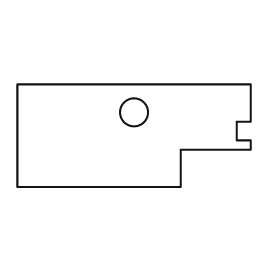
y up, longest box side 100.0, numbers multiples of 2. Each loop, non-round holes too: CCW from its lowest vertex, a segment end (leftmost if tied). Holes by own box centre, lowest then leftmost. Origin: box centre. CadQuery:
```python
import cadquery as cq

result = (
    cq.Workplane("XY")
    .moveTo(-50.0, -22.0)
    .lineTo(20.0, -22.0)
    .lineTo(20.0, -6.0)
    .lineTo(50.0, -6.0)
    .lineTo(50.0, -2.0)
    .lineTo(44.0, -2.0)
    .lineTo(44.0, 6.0)
    .lineTo(50.0, 6.0)
    .lineTo(50.0, 22.0)
    .lineTo(-50.0, 22.0)
    .close()
    .moveTo(0.0, 10.0)
    .circle(6.0)
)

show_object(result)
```